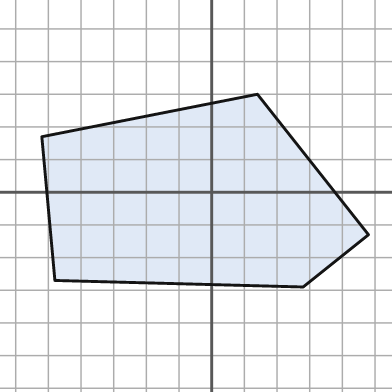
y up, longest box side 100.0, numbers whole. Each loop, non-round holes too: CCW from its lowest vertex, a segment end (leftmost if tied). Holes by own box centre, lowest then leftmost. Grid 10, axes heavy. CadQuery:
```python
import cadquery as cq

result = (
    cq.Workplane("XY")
    .moveTo(28.0, -29.0)
    .lineTo(48.0, -13.0)
    .lineTo(14.0, 30.0)
    .lineTo(-52.0, 17.0)
    .lineTo(-48.0, -27.0)
    .close()
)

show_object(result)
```